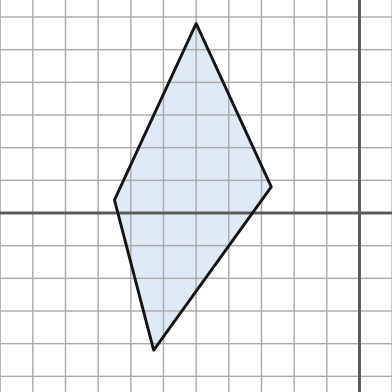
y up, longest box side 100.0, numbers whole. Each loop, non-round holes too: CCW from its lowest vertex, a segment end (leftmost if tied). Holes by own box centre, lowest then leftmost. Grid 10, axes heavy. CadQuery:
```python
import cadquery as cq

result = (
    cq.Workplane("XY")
    .moveTo(-63.0, -42.0)
    .lineTo(-27.0, 8.0)
    .lineTo(-50.0, 58.0)
    .lineTo(-75.0, 4.0)
    .close()
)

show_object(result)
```